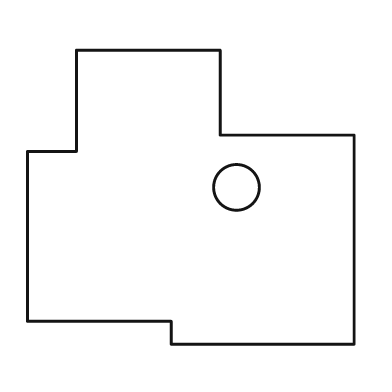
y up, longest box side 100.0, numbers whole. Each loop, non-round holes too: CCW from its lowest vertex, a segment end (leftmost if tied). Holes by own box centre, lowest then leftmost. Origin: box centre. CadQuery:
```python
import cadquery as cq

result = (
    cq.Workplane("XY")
    .moveTo(-6.0, -45.0)
    .lineTo(50.0, -45.0)
    .lineTo(50.0, 19.0)
    .lineTo(9.0, 19.0)
    .lineTo(9.0, 45.0)
    .lineTo(-35.0, 45.0)
    .lineTo(-35.0, 14.0)
    .lineTo(-50.0, 14.0)
    .lineTo(-50.0, -38.0)
    .lineTo(-6.0, -38.0)
    .close()
    .moveTo(14.0, 3.0)
    .circle(7.0)
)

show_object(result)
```